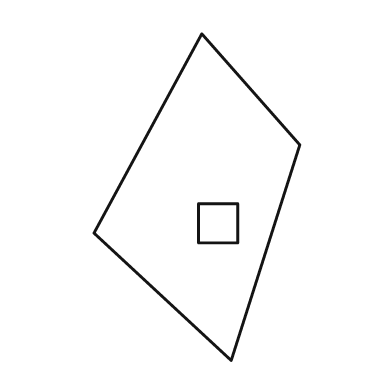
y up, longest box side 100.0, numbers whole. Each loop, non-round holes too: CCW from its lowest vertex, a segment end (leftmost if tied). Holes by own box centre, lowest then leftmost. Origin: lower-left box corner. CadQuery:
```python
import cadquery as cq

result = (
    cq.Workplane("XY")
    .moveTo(42.0, 0.0)
    .lineTo(63.0, 66.0)
    .lineTo(33.0, 100.0)
    .lineTo(0.0, 39.0)
    .close()
    .moveTo(32.0, 36.0)
    .lineTo(44.0, 36.0)
    .lineTo(44.0, 48.0)
    .lineTo(32.0, 48.0)
    .close()
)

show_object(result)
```